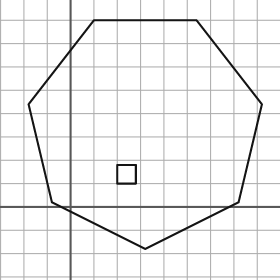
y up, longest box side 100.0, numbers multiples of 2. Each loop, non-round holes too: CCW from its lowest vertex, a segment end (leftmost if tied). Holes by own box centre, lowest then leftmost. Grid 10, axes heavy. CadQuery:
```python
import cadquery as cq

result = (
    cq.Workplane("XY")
    .moveTo(32.0, -18.0)
    .lineTo(72.0, 2.0)
    .lineTo(82.0, 44.0)
    .lineTo(54.0, 80.0)
    .lineTo(10.0, 80.0)
    .lineTo(-18.0, 44.0)
    .lineTo(-8.0, 2.0)
    .close()
    .moveTo(20.0, 10.0)
    .lineTo(28.0, 10.0)
    .lineTo(28.0, 18.0)
    .lineTo(20.0, 18.0)
    .close()
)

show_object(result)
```